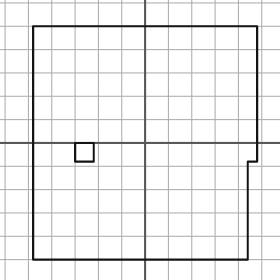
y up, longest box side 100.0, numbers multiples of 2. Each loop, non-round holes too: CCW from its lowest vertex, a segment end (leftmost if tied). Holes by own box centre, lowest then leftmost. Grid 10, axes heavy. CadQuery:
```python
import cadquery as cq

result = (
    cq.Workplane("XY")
    .moveTo(-48.0, -50.0)
    .lineTo(44.0, -50.0)
    .lineTo(44.0, -8.0)
    .lineTo(48.0, -8.0)
    .lineTo(48.0, 50.0)
    .lineTo(-48.0, 50.0)
    .close()
    .moveTo(-30.0, -8.0)
    .lineTo(-22.0, -8.0)
    .lineTo(-22.0, 0.0)
    .lineTo(-30.0, 0.0)
    .close()
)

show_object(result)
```